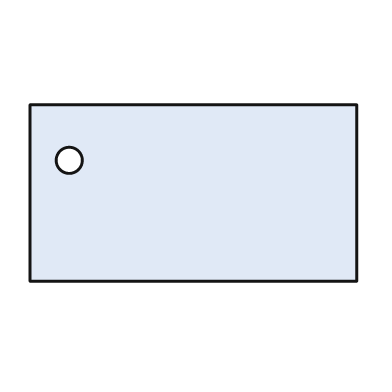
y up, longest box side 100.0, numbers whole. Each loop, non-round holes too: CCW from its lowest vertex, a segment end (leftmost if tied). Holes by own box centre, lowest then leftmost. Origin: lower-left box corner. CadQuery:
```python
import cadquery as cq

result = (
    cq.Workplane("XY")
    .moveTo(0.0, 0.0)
    .lineTo(100.0, 0.0)
    .lineTo(100.0, 54.0)
    .lineTo(0.0, 54.0)
    .close()
    .moveTo(12.0, 37.0)
    .circle(4.0)
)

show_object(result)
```